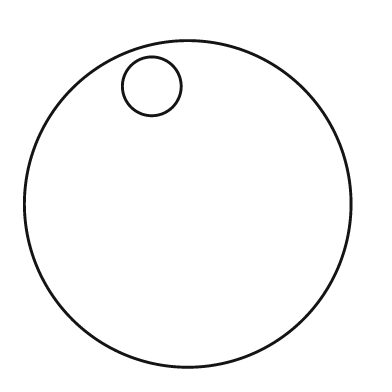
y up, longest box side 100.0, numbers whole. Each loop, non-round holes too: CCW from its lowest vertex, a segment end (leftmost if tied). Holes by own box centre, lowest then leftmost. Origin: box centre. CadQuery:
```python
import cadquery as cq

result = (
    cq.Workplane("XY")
    .moveTo(0.0, 0.0)
    .circle(50.0)
    .moveTo(-11.0, 36.0)
    .circle(9.0)
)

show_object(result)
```